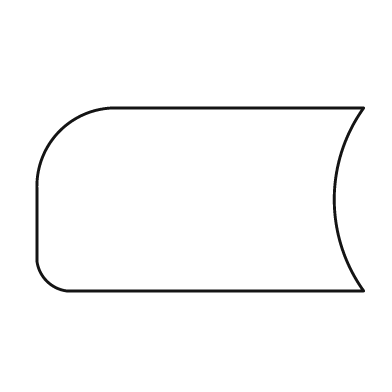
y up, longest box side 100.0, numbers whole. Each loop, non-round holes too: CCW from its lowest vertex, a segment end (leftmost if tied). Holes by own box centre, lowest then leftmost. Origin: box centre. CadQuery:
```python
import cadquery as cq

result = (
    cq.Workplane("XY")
    .moveTo(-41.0, -28.0)
    .lineTo(50.0, -28.0)
    .threePointArc((41.0, 0.0), (50.0, 28.0))
    .lineTo(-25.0, 28.0)
    .threePointArc((-43.0, 21.0), (-50.0, 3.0))
    .lineTo(-50.0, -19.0)
    .threePointArc((-47.0, -25.0), (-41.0, -28.0))
    .close()
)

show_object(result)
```